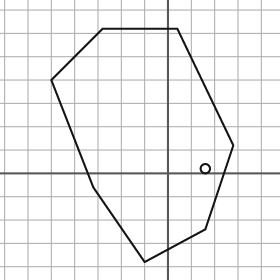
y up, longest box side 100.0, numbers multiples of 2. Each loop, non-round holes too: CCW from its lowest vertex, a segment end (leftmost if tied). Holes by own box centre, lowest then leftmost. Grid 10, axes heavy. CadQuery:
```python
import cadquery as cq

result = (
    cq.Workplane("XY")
    .moveTo(-10.0, -38.0)
    .lineTo(16.0, -24.0)
    .lineTo(28.0, 12.0)
    .lineTo(4.0, 62.0)
    .lineTo(-28.0, 62.0)
    .lineTo(-50.0, 40.0)
    .lineTo(-32.0, -6.0)
    .close()
    .moveTo(16.0, 2.0)
    .circle(2.0)
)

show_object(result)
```